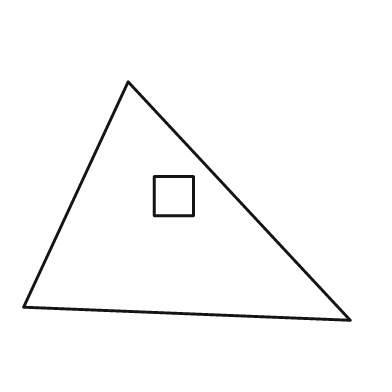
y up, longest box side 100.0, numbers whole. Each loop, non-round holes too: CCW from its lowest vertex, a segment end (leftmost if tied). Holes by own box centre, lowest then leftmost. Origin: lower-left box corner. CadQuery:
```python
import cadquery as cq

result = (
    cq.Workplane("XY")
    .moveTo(100.0, 0.0)
    .lineTo(32.0, 73.0)
    .lineTo(0.0, 4.0)
    .close()
    .moveTo(40.0, 32.0)
    .lineTo(52.0, 32.0)
    .lineTo(52.0, 44.0)
    .lineTo(40.0, 44.0)
    .close()
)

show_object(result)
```